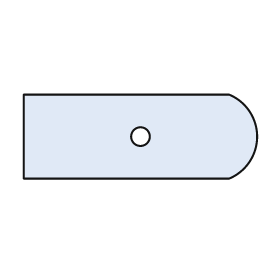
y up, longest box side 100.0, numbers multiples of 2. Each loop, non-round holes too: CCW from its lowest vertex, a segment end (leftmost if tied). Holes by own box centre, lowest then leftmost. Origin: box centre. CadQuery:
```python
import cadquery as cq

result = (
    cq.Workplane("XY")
    .moveTo(-50.0, -18.0)
    .lineTo(38.0, -18.0)
    .threePointArc((50.0, 0.0), (38.0, 18.0))
    .lineTo(-50.0, 18.0)
    .close()
    .moveTo(0.0, 0.0)
    .circle(4.0)
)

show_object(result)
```